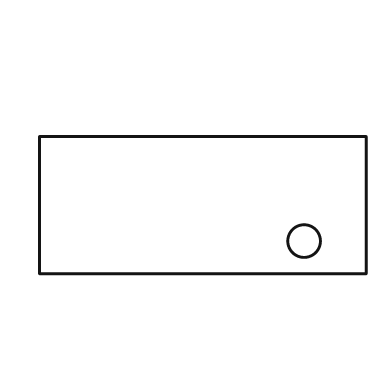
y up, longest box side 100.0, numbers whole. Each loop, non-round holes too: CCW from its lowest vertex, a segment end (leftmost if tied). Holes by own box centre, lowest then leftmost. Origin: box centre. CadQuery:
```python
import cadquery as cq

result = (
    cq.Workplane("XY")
    .moveTo(-50.0, -21.0)
    .lineTo(50.0, -21.0)
    .lineTo(50.0, 21.0)
    .lineTo(-50.0, 21.0)
    .close()
    .moveTo(31.0, -11.0)
    .circle(5.0)
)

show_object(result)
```